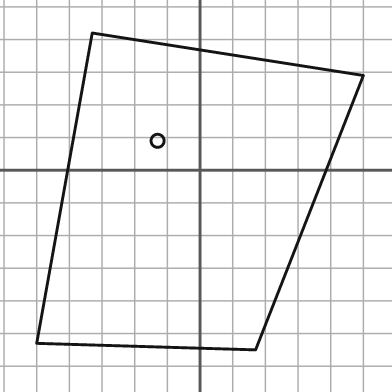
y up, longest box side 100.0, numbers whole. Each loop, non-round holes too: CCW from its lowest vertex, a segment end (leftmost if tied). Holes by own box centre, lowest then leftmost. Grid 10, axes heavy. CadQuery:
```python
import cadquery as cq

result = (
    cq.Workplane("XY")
    .moveTo(17.0, -55.0)
    .lineTo(50.0, 29.0)
    .lineTo(-33.0, 42.0)
    .lineTo(-50.0, -53.0)
    .close()
    .moveTo(-13.0, 9.0)
    .circle(2.0)
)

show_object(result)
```